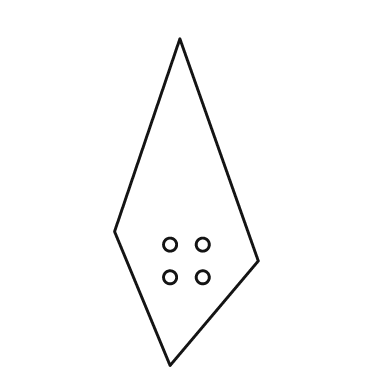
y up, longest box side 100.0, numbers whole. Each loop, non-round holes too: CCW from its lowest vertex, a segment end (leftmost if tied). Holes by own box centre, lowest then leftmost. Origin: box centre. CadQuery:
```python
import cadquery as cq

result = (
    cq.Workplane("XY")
    .moveTo(-5.0, -50.0)
    .lineTo(22.0, -18.0)
    .lineTo(-2.0, 50.0)
    .lineTo(-22.0, -9.0)
    .close()
    .moveTo(-5.0, -23.0)
    .circle(2.0)
    .moveTo(5.0, -23.0)
    .circle(2.0)
    .moveTo(-5.0, -13.0)
    .circle(2.0)
    .moveTo(5.0, -13.0)
    .circle(2.0)
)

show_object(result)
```